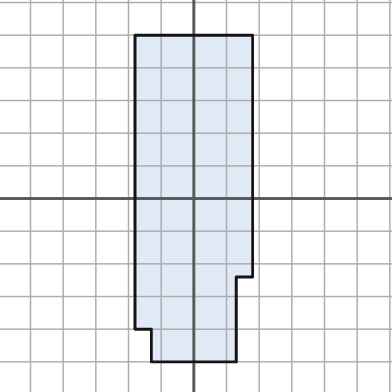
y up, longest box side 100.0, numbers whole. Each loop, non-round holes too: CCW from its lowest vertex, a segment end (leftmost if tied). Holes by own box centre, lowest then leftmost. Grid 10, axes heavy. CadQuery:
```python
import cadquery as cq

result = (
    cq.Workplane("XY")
    .moveTo(-13.0, -50.0)
    .lineTo(13.0, -50.0)
    .lineTo(13.0, -24.0)
    .lineTo(18.0, -24.0)
    .lineTo(18.0, 50.0)
    .lineTo(-18.0, 50.0)
    .lineTo(-18.0, -40.0)
    .lineTo(-13.0, -40.0)
    .close()
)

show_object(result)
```